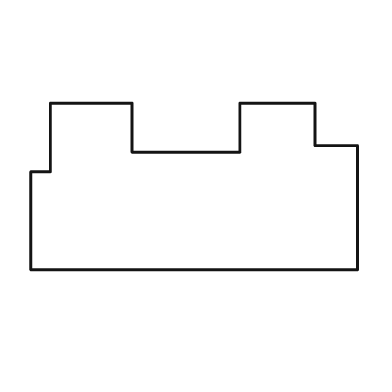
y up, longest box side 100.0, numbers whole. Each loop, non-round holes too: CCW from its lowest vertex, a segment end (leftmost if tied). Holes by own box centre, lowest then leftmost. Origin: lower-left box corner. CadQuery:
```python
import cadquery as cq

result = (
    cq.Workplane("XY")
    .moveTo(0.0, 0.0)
    .lineTo(100.0, 0.0)
    .lineTo(100.0, 38.0)
    .lineTo(87.0, 38.0)
    .lineTo(87.0, 51.0)
    .lineTo(64.0, 51.0)
    .lineTo(64.0, 36.0)
    .lineTo(31.0, 36.0)
    .lineTo(31.0, 51.0)
    .lineTo(6.0, 51.0)
    .lineTo(6.0, 30.0)
    .lineTo(0.0, 30.0)
    .close()
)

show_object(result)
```